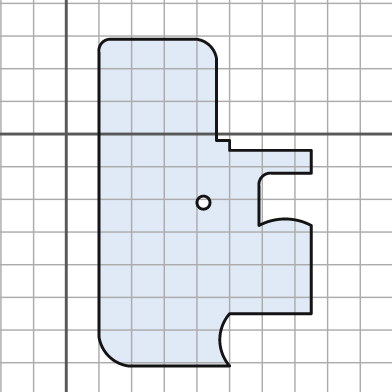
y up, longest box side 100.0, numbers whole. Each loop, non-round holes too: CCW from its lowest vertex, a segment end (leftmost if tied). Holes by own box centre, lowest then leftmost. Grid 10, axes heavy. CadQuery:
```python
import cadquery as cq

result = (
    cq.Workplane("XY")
    .moveTo(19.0, -71.0)
    .lineTo(50.0, -71.0)
    .threePointArc((47.0, -63.0), (50.0, -55.0))
    .lineTo(75.0, -55.0)
    .lineTo(75.0, -28.0)
    .threePointArc((67.0, -26.0), (59.0, -28.0))
    .lineTo(59.0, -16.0)
    .threePointArc((60.0, -13.0), (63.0, -12.0))
    .lineTo(75.0, -12.0)
    .lineTo(75.0, -5.0)
    .lineTo(50.0, -5.0)
    .lineTo(50.0, -2.0)
    .lineTo(46.0, -2.0)
    .lineTo(46.0, 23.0)
    .threePointArc((44.0, 27.0), (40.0, 29.0))
    .lineTo(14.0, 29.0)
    .threePointArc((11.0, 28.0), (10.0, 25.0))
    .lineTo(10.0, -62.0)
    .threePointArc((13.0, -68.0), (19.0, -71.0))
    .close()
    .moveTo(42.0, -21.0)
    .circle(2.0)
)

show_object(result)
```